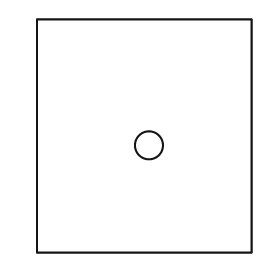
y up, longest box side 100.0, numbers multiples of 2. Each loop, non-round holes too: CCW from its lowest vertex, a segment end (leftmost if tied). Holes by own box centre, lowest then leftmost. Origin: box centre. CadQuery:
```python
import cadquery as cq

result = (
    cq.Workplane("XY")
    .moveTo(-46.0, -50.0)
    .lineTo(46.0, -50.0)
    .lineTo(46.0, 50.0)
    .lineTo(-46.0, 50.0)
    .close()
    .moveTo(2.0, -4.0)
    .circle(6.0)
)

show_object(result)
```